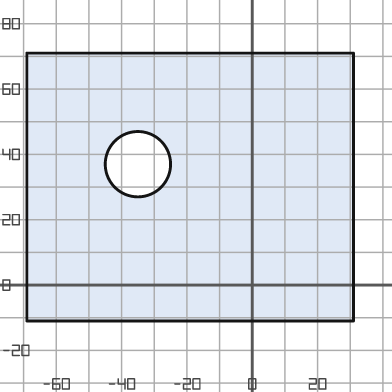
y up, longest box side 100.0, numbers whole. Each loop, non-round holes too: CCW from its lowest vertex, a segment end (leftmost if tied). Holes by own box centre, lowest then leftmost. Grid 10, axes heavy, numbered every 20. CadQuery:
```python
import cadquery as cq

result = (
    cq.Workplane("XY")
    .moveTo(-69.0, -11.0)
    .lineTo(31.0, -11.0)
    .lineTo(31.0, 71.0)
    .lineTo(-69.0, 71.0)
    .close()
    .moveTo(-35.0, 37.0)
    .circle(10.0)
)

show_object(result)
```